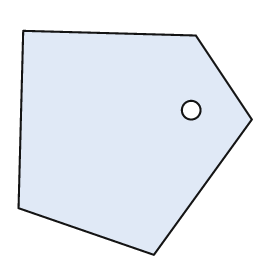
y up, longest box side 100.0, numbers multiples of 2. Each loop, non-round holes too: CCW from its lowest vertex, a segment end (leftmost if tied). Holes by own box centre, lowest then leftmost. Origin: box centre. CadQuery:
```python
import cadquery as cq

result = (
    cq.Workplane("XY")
    .moveTo(8.0, -48.0)
    .lineTo(50.0, 10.0)
    .lineTo(26.0, 46.0)
    .lineTo(-48.0, 48.0)
    .lineTo(-50.0, -28.0)
    .close()
    .moveTo(24.0, 14.0)
    .circle(4.0)
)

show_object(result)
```